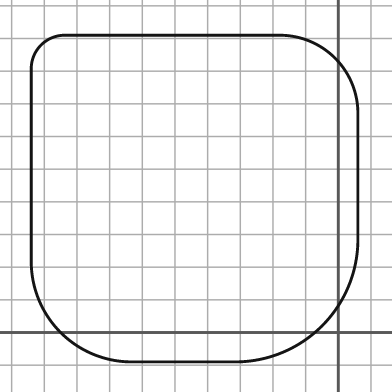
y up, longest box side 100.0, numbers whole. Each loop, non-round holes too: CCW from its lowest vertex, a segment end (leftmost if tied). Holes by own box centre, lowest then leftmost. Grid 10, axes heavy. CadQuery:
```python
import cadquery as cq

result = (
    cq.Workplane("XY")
    .moveTo(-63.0, -9.0)
    .lineTo(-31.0, -9.0)
    .threePointArc((-5.0, 2.0), (6.0, 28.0))
    .lineTo(6.0, 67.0)
    .threePointArc((-1.0, 84.0), (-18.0, 91.0))
    .lineTo(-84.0, 91.0)
    .threePointArc((-91.0, 88.0), (-94.0, 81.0))
    .lineTo(-94.0, 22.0)
    .threePointArc((-85.0, 0.0), (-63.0, -9.0))
    .close()
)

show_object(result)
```